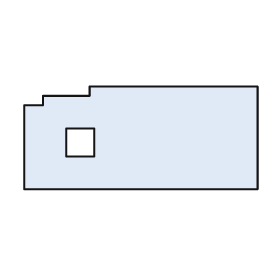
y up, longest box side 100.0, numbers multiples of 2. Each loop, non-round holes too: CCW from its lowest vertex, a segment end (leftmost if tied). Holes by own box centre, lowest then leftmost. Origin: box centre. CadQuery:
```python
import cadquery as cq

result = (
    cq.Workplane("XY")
    .moveTo(-50.0, -22.0)
    .lineTo(50.0, -22.0)
    .lineTo(50.0, 22.0)
    .lineTo(-22.0, 22.0)
    .lineTo(-22.0, 18.0)
    .lineTo(-42.0, 18.0)
    .lineTo(-42.0, 14.0)
    .lineTo(-50.0, 14.0)
    .close()
    .moveTo(-32.0, -8.0)
    .lineTo(-20.0, -8.0)
    .lineTo(-20.0, 4.0)
    .lineTo(-32.0, 4.0)
    .close()
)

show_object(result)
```